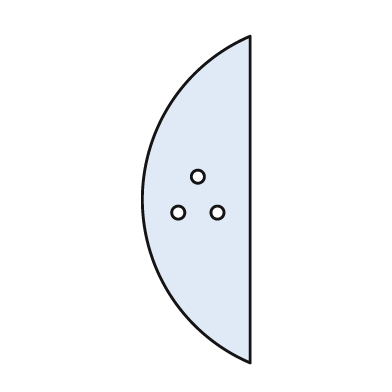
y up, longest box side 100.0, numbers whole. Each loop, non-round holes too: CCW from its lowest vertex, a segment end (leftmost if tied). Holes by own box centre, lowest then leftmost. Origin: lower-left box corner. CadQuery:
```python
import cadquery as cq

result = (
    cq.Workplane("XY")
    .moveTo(33.0, 0.0)
    .lineTo(33.0, 100.0)
    .threePointArc((0.0, 50.0), (33.0, 0.0))
    .close()
    .moveTo(11.0, 46.0)
    .circle(2.0)
    .moveTo(23.0, 46.0)
    .circle(2.0)
    .moveTo(17.0, 57.0)
    .circle(2.0)
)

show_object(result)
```